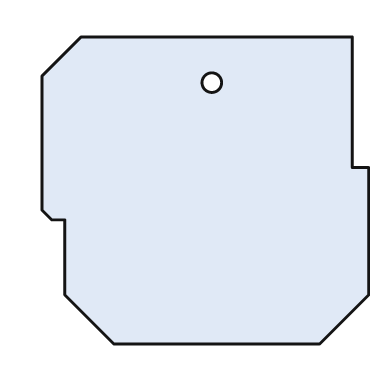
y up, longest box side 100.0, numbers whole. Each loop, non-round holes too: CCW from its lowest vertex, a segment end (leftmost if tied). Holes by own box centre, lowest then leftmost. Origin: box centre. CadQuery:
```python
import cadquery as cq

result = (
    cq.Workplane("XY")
    .moveTo(-28.0, -47.0)
    .lineTo(35.0, -47.0)
    .lineTo(50.0, -32.0)
    .lineTo(50.0, 7.0)
    .lineTo(45.0, 7.0)
    .lineTo(45.0, 47.0)
    .lineTo(-38.0, 47.0)
    .lineTo(-50.0, 35.0)
    .lineTo(-50.0, -6.0)
    .lineTo(-47.0, -9.0)
    .lineTo(-43.0, -9.0)
    .lineTo(-43.0, -32.0)
    .close()
    .moveTo(2.0, 33.0)
    .circle(3.0)
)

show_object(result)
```